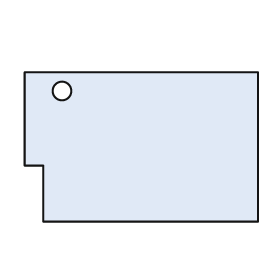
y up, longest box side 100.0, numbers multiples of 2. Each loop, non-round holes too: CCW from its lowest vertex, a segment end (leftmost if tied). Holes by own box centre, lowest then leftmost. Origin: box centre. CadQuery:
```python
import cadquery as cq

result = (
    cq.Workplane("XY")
    .moveTo(-42.0, -32.0)
    .lineTo(50.0, -32.0)
    .lineTo(50.0, 32.0)
    .lineTo(-50.0, 32.0)
    .lineTo(-50.0, -8.0)
    .lineTo(-42.0, -8.0)
    .close()
    .moveTo(-34.0, 24.0)
    .circle(4.0)
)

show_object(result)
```